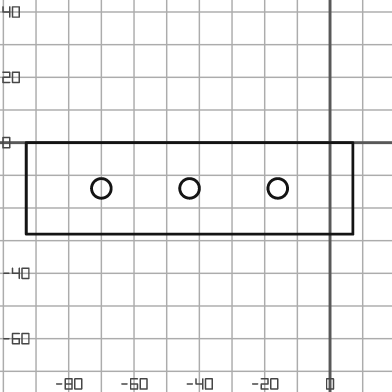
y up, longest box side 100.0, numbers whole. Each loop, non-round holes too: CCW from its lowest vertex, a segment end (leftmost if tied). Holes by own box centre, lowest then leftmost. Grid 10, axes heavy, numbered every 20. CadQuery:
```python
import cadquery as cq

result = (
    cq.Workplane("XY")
    .moveTo(-93.0, -28.0)
    .lineTo(7.0, -28.0)
    .lineTo(7.0, 0.0)
    .lineTo(-93.0, 0.0)
    .close()
    .moveTo(-70.0, -14.0)
    .circle(3.0)
    .moveTo(-43.0, -14.0)
    .circle(3.0)
    .moveTo(-16.0, -14.0)
    .circle(3.0)
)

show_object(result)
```